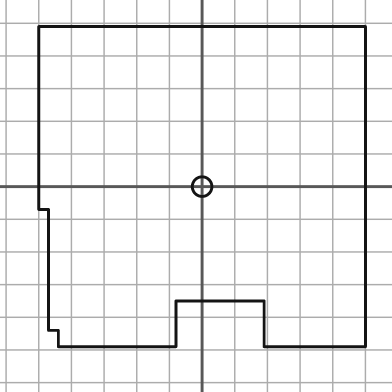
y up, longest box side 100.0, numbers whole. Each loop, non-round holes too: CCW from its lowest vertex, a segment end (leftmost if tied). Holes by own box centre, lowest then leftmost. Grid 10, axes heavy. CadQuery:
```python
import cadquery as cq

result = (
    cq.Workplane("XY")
    .moveTo(-44.0, -49.0)
    .lineTo(-8.0, -49.0)
    .lineTo(-8.0, -35.0)
    .lineTo(19.0, -35.0)
    .lineTo(19.0, -49.0)
    .lineTo(50.0, -49.0)
    .lineTo(50.0, 49.0)
    .lineTo(-50.0, 49.0)
    .lineTo(-50.0, -7.0)
    .lineTo(-47.0, -7.0)
    .lineTo(-47.0, -44.0)
    .lineTo(-44.0, -44.0)
    .close()
    .moveTo(0.0, 0.0)
    .circle(3.0)
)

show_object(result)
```